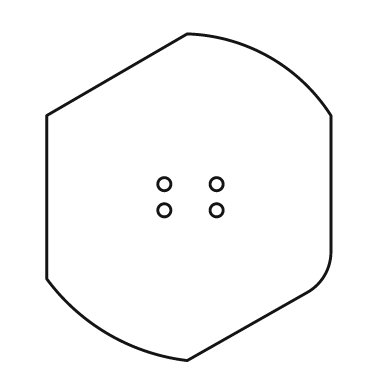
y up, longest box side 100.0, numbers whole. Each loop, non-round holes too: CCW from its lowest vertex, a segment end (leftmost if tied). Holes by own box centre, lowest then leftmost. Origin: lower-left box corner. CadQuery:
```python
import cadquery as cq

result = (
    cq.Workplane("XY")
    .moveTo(43.0, 0.0)
    .lineTo(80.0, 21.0)
    .threePointArc((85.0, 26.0), (87.0, 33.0))
    .lineTo(87.0, 75.0)
    .threePointArc((68.0, 93.0), (43.0, 100.0))
    .lineTo(0.0, 75.0)
    .lineTo(0.0, 25.0)
    .threePointArc((19.0, 8.0), (43.0, 0.0))
    .close()
    .moveTo(36.0, 46.0)
    .circle(2.0)
    .moveTo(52.0, 46.0)
    .circle(2.0)
    .moveTo(36.0, 54.0)
    .circle(2.0)
    .moveTo(52.0, 54.0)
    .circle(2.0)
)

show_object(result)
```